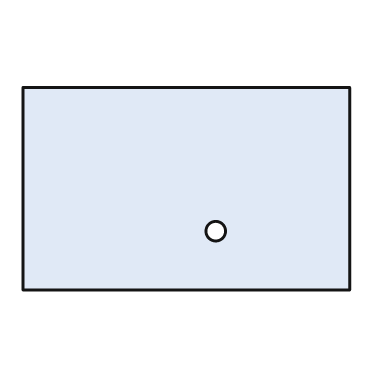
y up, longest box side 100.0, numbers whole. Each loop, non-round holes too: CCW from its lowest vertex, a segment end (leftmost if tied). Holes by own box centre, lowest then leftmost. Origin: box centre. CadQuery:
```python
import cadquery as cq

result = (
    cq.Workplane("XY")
    .moveTo(-50.0, -31.0)
    .lineTo(50.0, -31.0)
    .lineTo(50.0, 31.0)
    .lineTo(-50.0, 31.0)
    .close()
    .moveTo(9.0, -13.0)
    .circle(3.0)
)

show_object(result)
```